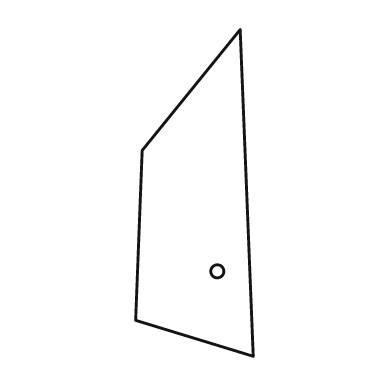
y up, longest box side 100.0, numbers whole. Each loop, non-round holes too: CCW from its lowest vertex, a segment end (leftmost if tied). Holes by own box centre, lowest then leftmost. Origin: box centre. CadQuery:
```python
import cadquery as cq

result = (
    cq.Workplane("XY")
    .moveTo(18.0, -50.0)
    .lineTo(14.0, 50.0)
    .lineTo(-16.0, 13.0)
    .lineTo(-18.0, -39.0)
    .close()
    .moveTo(7.0, -24.0)
    .circle(2.0)
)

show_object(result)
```